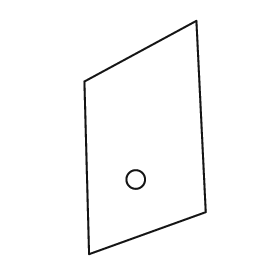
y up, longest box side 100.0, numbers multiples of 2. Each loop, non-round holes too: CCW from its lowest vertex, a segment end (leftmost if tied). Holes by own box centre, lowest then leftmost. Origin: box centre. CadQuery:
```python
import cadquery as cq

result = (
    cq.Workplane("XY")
    .moveTo(-24.0, -50.0)
    .lineTo(26.0, -32.0)
    .lineTo(22.0, 50.0)
    .lineTo(-26.0, 24.0)
    .close()
    .moveTo(-4.0, -18.0)
    .circle(4.0)
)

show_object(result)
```